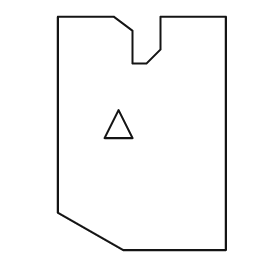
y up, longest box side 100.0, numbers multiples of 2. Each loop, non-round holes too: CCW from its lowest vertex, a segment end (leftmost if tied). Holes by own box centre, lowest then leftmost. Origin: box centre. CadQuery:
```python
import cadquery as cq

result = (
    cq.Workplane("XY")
    .moveTo(-8.0, -50.0)
    .lineTo(36.0, -50.0)
    .lineTo(36.0, 50.0)
    .lineTo(8.0, 50.0)
    .lineTo(8.0, 36.0)
    .lineTo(2.0, 30.0)
    .lineTo(-4.0, 30.0)
    .lineTo(-4.0, 44.0)
    .lineTo(-12.0, 50.0)
    .lineTo(-36.0, 50.0)
    .lineTo(-36.0, -34.0)
    .close()
    .moveTo(-16.0, -2.0)
    .lineTo(-4.0, -2.0)
    .lineTo(-10.0, 10.0)
    .close()
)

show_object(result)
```